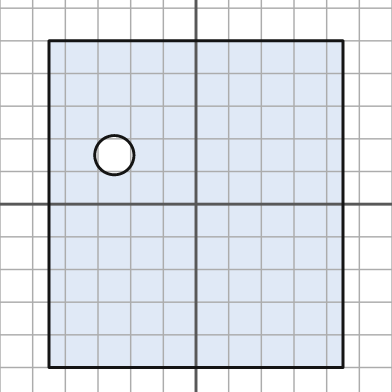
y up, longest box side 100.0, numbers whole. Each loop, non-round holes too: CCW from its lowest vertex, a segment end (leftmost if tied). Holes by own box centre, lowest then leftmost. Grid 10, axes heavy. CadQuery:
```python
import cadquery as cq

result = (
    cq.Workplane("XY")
    .moveTo(-45.0, -50.0)
    .lineTo(45.0, -50.0)
    .lineTo(45.0, 50.0)
    .lineTo(-45.0, 50.0)
    .close()
    .moveTo(-25.0, 15.0)
    .circle(6.0)
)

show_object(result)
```